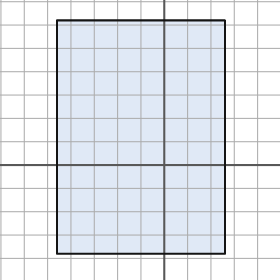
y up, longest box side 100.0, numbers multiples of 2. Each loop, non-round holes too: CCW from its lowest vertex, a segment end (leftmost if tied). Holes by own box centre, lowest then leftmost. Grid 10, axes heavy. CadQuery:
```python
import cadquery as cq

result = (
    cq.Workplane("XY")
    .moveTo(-46.0, -38.0)
    .lineTo(26.0, -38.0)
    .lineTo(26.0, 62.0)
    .lineTo(-46.0, 62.0)
    .close()
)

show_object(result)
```